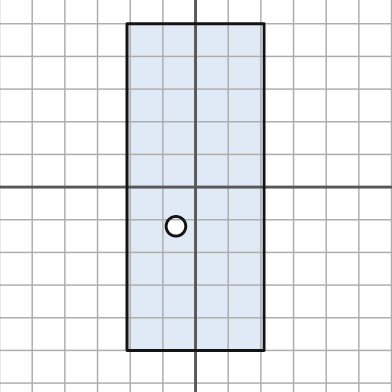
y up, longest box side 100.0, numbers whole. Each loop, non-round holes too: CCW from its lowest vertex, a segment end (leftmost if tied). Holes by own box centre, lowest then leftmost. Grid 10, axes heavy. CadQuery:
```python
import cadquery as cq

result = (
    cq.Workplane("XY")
    .moveTo(-21.0, -50.0)
    .lineTo(21.0, -50.0)
    .lineTo(21.0, 50.0)
    .lineTo(-21.0, 50.0)
    .close()
    .moveTo(-6.0, -12.0)
    .circle(3.0)
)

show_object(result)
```